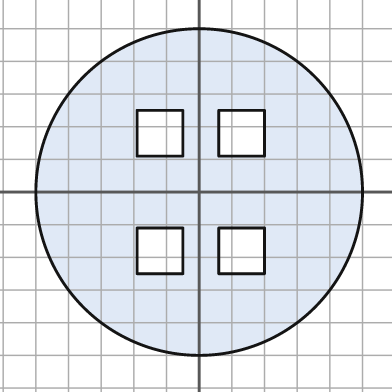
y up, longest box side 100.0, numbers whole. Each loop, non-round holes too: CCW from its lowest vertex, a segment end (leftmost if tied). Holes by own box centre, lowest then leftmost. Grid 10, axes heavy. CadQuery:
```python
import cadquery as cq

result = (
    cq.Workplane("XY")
    .moveTo(0.0, 0.0)
    .circle(50.0)
    .moveTo(-19.0, -25.0)
    .lineTo(-5.0, -25.0)
    .lineTo(-5.0, -11.0)
    .lineTo(-19.0, -11.0)
    .close()
    .moveTo(6.0, -25.0)
    .lineTo(20.0, -25.0)
    .lineTo(20.0, -11.0)
    .lineTo(6.0, -11.0)
    .close()
    .moveTo(-19.0, 11.0)
    .lineTo(-5.0, 11.0)
    .lineTo(-5.0, 25.0)
    .lineTo(-19.0, 25.0)
    .close()
    .moveTo(6.0, 11.0)
    .lineTo(20.0, 11.0)
    .lineTo(20.0, 25.0)
    .lineTo(6.0, 25.0)
    .close()
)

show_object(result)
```